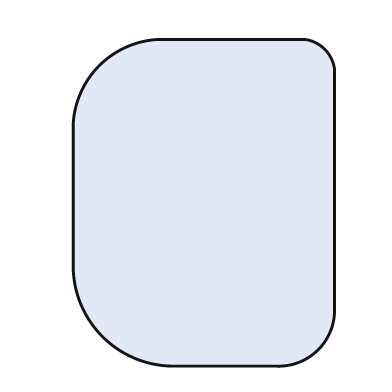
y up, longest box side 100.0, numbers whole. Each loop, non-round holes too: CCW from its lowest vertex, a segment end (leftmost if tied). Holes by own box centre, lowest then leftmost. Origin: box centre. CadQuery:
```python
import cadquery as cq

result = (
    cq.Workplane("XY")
    .moveTo(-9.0, -50.0)
    .lineTo(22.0, -50.0)
    .threePointArc((35.0, -45.0), (40.0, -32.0))
    .lineTo(40.0, 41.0)
    .threePointArc((37.0, 47.0), (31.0, 50.0))
    .lineTo(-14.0, 50.0)
    .threePointArc((-32.0, 42.0), (-40.0, 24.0))
    .lineTo(-40.0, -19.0)
    .threePointArc((-31.0, -41.0), (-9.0, -50.0))
    .close()
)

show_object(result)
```